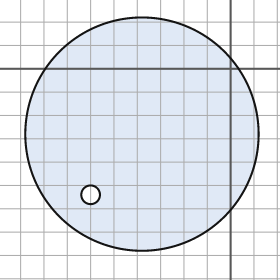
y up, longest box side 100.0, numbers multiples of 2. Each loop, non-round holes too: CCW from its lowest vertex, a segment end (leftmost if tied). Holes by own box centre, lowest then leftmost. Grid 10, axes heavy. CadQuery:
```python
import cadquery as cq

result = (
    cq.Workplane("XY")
    .moveTo(-38.0, -28.0)
    .circle(50.0)
    .moveTo(-60.0, -54.0)
    .circle(4.0)
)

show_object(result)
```